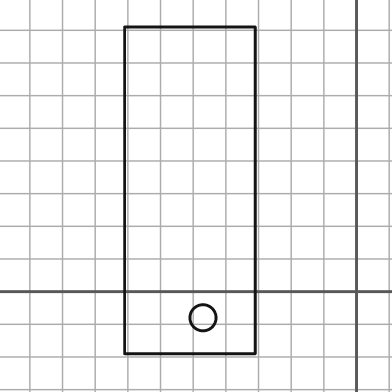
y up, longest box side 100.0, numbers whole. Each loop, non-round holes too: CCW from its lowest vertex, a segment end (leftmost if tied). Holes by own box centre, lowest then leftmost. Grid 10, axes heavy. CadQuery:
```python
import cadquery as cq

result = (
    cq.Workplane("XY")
    .moveTo(-71.0, -19.0)
    .lineTo(-31.0, -19.0)
    .lineTo(-31.0, 81.0)
    .lineTo(-71.0, 81.0)
    .close()
    .moveTo(-47.0, -8.0)
    .circle(4.0)
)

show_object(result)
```